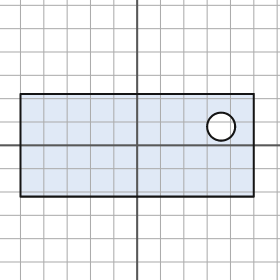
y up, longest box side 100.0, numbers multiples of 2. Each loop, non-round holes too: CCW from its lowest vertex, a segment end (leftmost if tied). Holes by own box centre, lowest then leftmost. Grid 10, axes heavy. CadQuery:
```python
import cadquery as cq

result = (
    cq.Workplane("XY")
    .moveTo(-50.0, -22.0)
    .lineTo(50.0, -22.0)
    .lineTo(50.0, 22.0)
    .lineTo(-50.0, 22.0)
    .close()
    .moveTo(36.0, 8.0)
    .circle(6.0)
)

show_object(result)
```